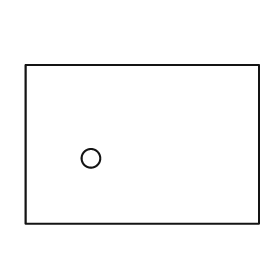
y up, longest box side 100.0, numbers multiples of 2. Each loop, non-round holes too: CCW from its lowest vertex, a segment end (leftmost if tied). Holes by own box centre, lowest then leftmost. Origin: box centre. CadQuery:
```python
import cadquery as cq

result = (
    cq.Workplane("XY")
    .moveTo(-50.0, -34.0)
    .lineTo(50.0, -34.0)
    .lineTo(50.0, 34.0)
    .lineTo(-50.0, 34.0)
    .close()
    .moveTo(-22.0, -6.0)
    .circle(4.0)
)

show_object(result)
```